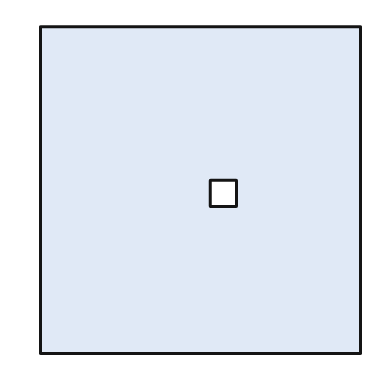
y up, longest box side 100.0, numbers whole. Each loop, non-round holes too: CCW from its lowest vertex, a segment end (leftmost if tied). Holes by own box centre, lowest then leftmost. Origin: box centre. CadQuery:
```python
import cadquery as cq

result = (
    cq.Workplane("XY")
    .moveTo(-49.0, -50.0)
    .lineTo(49.0, -50.0)
    .lineTo(49.0, 50.0)
    .lineTo(-49.0, 50.0)
    .close()
    .moveTo(3.0, -5.0)
    .lineTo(11.0, -5.0)
    .lineTo(11.0, 3.0)
    .lineTo(3.0, 3.0)
    .close()
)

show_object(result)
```